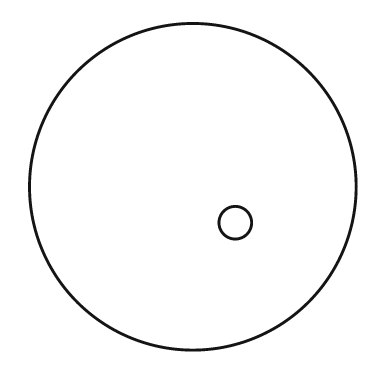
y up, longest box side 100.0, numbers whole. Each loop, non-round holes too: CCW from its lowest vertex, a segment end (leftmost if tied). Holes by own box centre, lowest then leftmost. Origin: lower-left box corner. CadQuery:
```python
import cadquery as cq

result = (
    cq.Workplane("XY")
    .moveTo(50.0, 50.0)
    .circle(50.0)
    .moveTo(63.0, 39.0)
    .circle(5.0)
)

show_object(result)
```